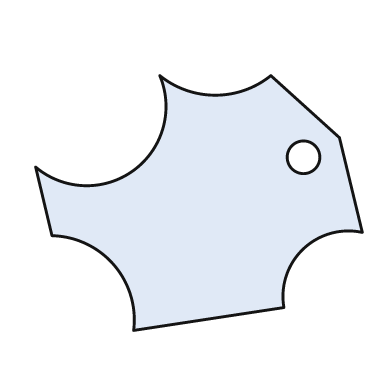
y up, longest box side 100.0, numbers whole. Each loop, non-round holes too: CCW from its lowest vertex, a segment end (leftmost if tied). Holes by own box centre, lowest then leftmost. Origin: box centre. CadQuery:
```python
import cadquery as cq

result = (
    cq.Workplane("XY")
    .moveTo(-20.0, -39.0)
    .lineTo(26.0, -32.0)
    .threePointArc((32.0, -14.0), (50.0, -9.0))
    .lineTo(43.0, 20.0)
    .lineTo(22.0, 39.0)
    .threePointArc((5.0, 33.0), (-12.0, 39.0))
    .threePointArc((-20.0, 10.0), (-50.0, 11.0))
    .lineTo(-45.0, -10.0)
    .threePointArc((-26.0, -19.0), (-20.0, -39.0))
    .close()
    .moveTo(32.0, 14.0)
    .circle(5.0)
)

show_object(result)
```